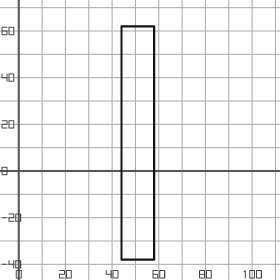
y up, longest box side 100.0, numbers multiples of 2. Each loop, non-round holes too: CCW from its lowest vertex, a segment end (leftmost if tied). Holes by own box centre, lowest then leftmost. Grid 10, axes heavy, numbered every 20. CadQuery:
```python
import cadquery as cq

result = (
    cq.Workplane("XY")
    .moveTo(44.0, -38.0)
    .lineTo(58.0, -38.0)
    .lineTo(58.0, 62.0)
    .lineTo(44.0, 62.0)
    .close()
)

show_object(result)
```